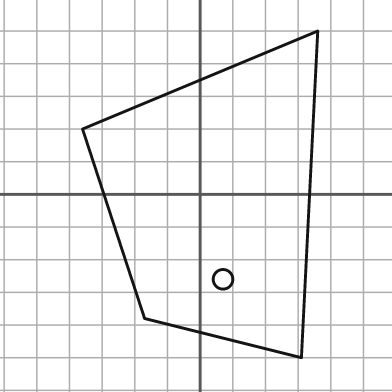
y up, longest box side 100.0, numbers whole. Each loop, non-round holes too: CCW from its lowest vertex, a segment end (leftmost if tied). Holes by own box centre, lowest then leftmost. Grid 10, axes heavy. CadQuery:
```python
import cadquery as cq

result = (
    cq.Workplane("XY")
    .moveTo(31.0, -50.0)
    .lineTo(36.0, 50.0)
    .lineTo(-36.0, 20.0)
    .lineTo(-17.0, -38.0)
    .close()
    .moveTo(7.0, -26.0)
    .circle(3.0)
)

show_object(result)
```